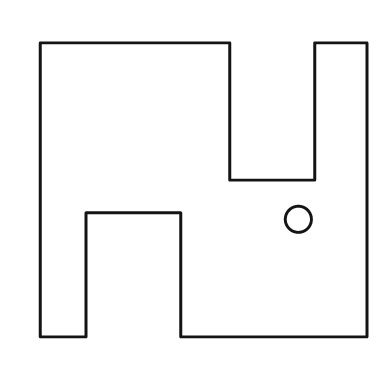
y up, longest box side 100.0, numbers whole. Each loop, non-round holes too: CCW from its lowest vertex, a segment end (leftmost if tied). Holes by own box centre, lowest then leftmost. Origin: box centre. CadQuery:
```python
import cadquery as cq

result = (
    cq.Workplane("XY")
    .moveTo(-50.0, -45.0)
    .lineTo(-36.0, -45.0)
    .lineTo(-36.0, -7.0)
    .lineTo(-7.0, -7.0)
    .lineTo(-7.0, -45.0)
    .lineTo(50.0, -45.0)
    .lineTo(50.0, 45.0)
    .lineTo(34.0, 45.0)
    .lineTo(34.0, 3.0)
    .lineTo(8.0, 3.0)
    .lineTo(8.0, 45.0)
    .lineTo(-50.0, 45.0)
    .close()
    .moveTo(29.0, -9.0)
    .circle(4.0)
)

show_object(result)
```